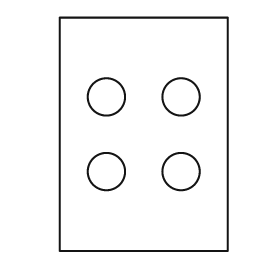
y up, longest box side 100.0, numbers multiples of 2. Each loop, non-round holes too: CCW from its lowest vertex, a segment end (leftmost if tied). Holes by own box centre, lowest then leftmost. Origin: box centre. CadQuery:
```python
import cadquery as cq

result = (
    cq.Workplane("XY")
    .moveTo(-36.0, -50.0)
    .lineTo(36.0, -50.0)
    .lineTo(36.0, 50.0)
    .lineTo(-36.0, 50.0)
    .close()
    .moveTo(-16.0, -16.0)
    .circle(8.0)
    .moveTo(16.0, -16.0)
    .circle(8.0)
    .moveTo(-16.0, 16.0)
    .circle(8.0)
    .moveTo(16.0, 16.0)
    .circle(8.0)
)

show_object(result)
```